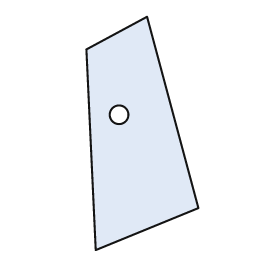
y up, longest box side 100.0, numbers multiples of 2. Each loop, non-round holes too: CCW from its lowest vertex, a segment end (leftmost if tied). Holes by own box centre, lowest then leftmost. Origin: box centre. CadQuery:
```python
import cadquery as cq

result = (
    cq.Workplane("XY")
    .moveTo(-20.0, -50.0)
    .lineTo(24.0, -32.0)
    .lineTo(2.0, 50.0)
    .lineTo(-24.0, 36.0)
    .close()
    .moveTo(-10.0, 8.0)
    .circle(4.0)
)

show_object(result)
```